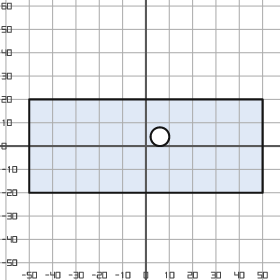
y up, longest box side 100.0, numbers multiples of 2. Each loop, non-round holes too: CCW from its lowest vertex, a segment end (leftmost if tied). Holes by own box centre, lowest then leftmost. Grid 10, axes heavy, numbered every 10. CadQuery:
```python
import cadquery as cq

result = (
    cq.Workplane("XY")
    .moveTo(-50.0, -20.0)
    .lineTo(50.0, -20.0)
    .lineTo(50.0, 20.0)
    .lineTo(-50.0, 20.0)
    .close()
    .moveTo(6.0, 4.0)
    .circle(4.0)
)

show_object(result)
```